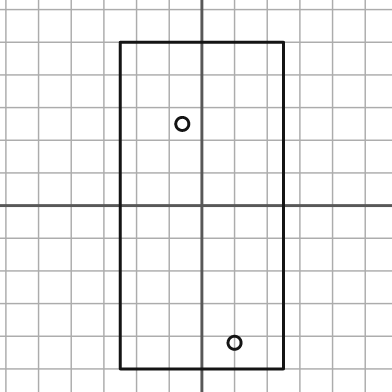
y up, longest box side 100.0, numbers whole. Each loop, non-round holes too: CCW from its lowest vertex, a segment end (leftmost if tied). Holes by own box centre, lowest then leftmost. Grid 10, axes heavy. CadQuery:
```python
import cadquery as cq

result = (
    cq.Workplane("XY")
    .moveTo(-25.0, -50.0)
    .lineTo(25.0, -50.0)
    .lineTo(25.0, 50.0)
    .lineTo(-25.0, 50.0)
    .close()
    .moveTo(10.0, -42.0)
    .circle(2.0)
    .moveTo(-6.0, 25.0)
    .circle(2.0)
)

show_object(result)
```